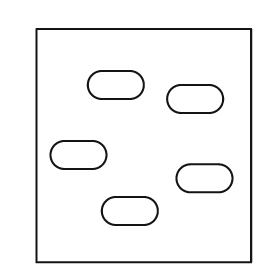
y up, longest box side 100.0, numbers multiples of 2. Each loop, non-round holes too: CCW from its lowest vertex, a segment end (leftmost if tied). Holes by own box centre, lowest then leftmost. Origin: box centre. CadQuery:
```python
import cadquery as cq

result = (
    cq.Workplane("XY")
    .moveTo(-46.0, -50.0)
    .lineTo(46.0, -50.0)
    .lineTo(46.0, 50.0)
    .lineTo(-46.0, 50.0)
    .close()
    .moveTo(-12.0, -34.0)
    .lineTo(0.0, -34.0)
    .threePointArc((6.0, -28.0), (0.0, -22.0))
    .lineTo(-12.0, -22.0)
    .threePointArc((-18.0, -28.0), (-12.0, -34.0))
    .close()
    .moveTo(20.0, -20.0)
    .lineTo(32.0, -20.0)
    .threePointArc((38.0, -14.0), (32.0, -8.0))
    .lineTo(20.0, -8.0)
    .threePointArc((14.0, -14.0), (20.0, -20.0))
    .close()
    .moveTo(-34.0, -10.0)
    .lineTo(-22.0, -10.0)
    .threePointArc((-16.0, -4.0), (-22.0, 2.0))
    .lineTo(-34.0, 2.0)
    .threePointArc((-40.0, -4.0), (-34.0, -10.0))
    .close()
    .moveTo(16.0, 14.0)
    .lineTo(28.0, 14.0)
    .threePointArc((34.0, 20.0), (28.0, 26.0))
    .lineTo(16.0, 26.0)
    .threePointArc((10.0, 20.0), (16.0, 14.0))
    .close()
    .moveTo(-18.0, 20.0)
    .lineTo(-6.0, 20.0)
    .threePointArc((0.0, 26.0), (-6.0, 32.0))
    .lineTo(-18.0, 32.0)
    .threePointArc((-24.0, 26.0), (-18.0, 20.0))
    .close()
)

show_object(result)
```